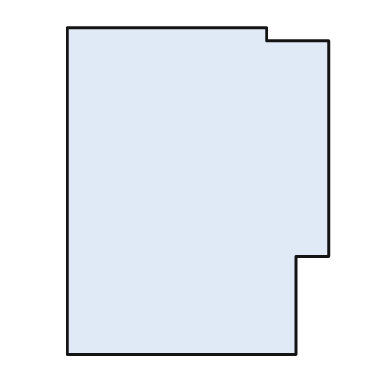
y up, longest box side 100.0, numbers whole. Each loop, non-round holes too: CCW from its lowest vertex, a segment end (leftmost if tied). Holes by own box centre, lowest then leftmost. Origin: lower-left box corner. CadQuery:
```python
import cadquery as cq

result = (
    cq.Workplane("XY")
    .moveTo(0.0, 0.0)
    .lineTo(70.0, 0.0)
    .lineTo(70.0, 30.0)
    .lineTo(80.0, 30.0)
    .lineTo(80.0, 96.0)
    .lineTo(61.0, 96.0)
    .lineTo(61.0, 100.0)
    .lineTo(0.0, 100.0)
    .close()
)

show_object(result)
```